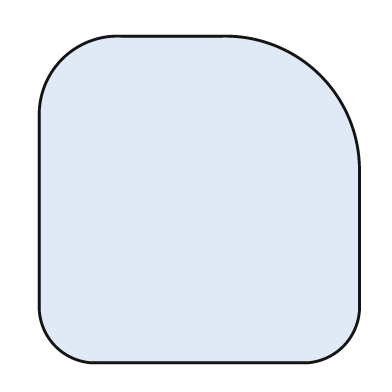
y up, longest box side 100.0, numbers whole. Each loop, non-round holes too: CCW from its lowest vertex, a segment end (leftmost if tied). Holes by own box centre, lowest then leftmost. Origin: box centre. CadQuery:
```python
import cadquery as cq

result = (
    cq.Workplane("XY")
    .moveTo(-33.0, -50.0)
    .lineTo(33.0, -50.0)
    .threePointArc((44.0, -45.0), (49.0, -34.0))
    .lineTo(49.0, 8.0)
    .threePointArc((37.0, 38.0), (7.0, 50.0))
    .lineTo(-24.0, 50.0)
    .threePointArc((-42.0, 43.0), (-49.0, 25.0))
    .lineTo(-49.0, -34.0)
    .threePointArc((-44.0, -45.0), (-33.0, -50.0))
    .close()
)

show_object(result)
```